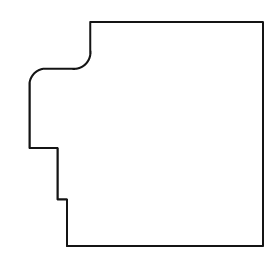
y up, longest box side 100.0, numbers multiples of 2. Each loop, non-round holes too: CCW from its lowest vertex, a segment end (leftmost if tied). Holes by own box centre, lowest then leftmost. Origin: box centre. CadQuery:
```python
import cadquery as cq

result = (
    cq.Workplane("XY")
    .moveTo(-34.0, -48.0)
    .lineTo(50.0, -48.0)
    .lineTo(50.0, 48.0)
    .lineTo(-24.0, 48.0)
    .lineTo(-24.0, 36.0)
    .threePointArc((-26.0, 30.0), (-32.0, 28.0))
    .lineTo(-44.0, 28.0)
    .threePointArc((-48.0, 26.0), (-50.0, 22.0))
    .lineTo(-50.0, -6.0)
    .lineTo(-38.0, -6.0)
    .lineTo(-38.0, -28.0)
    .lineTo(-34.0, -28.0)
    .close()
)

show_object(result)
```